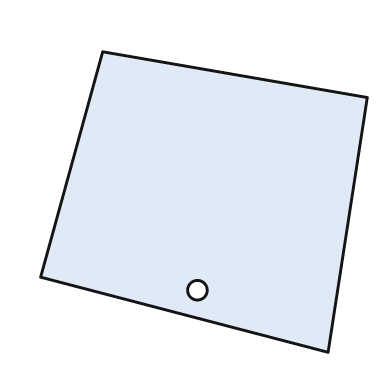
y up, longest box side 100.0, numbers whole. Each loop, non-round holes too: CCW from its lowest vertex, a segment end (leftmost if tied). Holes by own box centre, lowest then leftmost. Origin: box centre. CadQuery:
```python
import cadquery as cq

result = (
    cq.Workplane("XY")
    .moveTo(38.0, -46.0)
    .lineTo(50.0, 32.0)
    .lineTo(-31.0, 46.0)
    .lineTo(-50.0, -23.0)
    .close()
    .moveTo(-2.0, -27.0)
    .circle(3.0)
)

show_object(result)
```